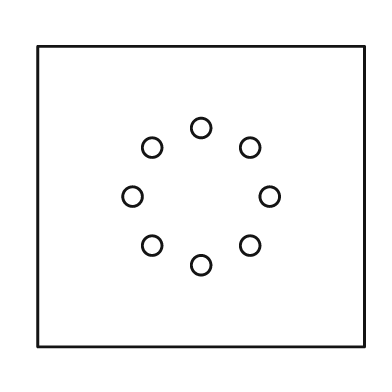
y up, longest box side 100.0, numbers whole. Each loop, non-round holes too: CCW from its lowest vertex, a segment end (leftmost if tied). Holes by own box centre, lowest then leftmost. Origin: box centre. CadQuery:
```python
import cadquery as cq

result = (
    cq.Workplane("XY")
    .moveTo(-50.0, -46.0)
    .lineTo(50.0, -46.0)
    .lineTo(50.0, 46.0)
    .lineTo(-50.0, 46.0)
    .close()
    .moveTo(0.0, -21.0)
    .circle(3.0)
    .moveTo(-15.0, -15.0)
    .circle(3.0)
    .moveTo(15.0, -15.0)
    .circle(3.0)
    .moveTo(-21.0, 0.0)
    .circle(3.0)
    .moveTo(21.0, 0.0)
    .circle(3.0)
    .moveTo(-15.0, 15.0)
    .circle(3.0)
    .moveTo(15.0, 15.0)
    .circle(3.0)
    .moveTo(0.0, 21.0)
    .circle(3.0)
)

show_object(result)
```